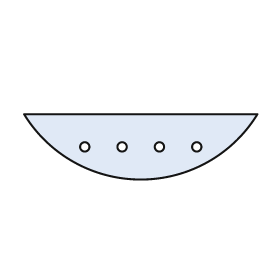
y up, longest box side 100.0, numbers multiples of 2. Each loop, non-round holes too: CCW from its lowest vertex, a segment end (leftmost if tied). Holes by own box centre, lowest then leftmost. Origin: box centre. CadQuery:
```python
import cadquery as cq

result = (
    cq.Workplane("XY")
    .moveTo(-50.0, 14.0)
    .threePointArc((0.0, -14.0), (50.0, 14.0))
    .close()
    .moveTo(-24.0, 0.0)
    .circle(2.0)
    .moveTo(-8.0, 0.0)
    .circle(2.0)
    .moveTo(8.0, 0.0)
    .circle(2.0)
    .moveTo(24.0, 0.0)
    .circle(2.0)
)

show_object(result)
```